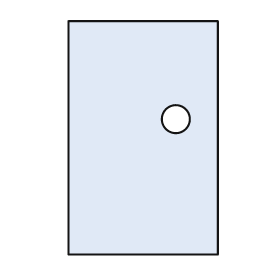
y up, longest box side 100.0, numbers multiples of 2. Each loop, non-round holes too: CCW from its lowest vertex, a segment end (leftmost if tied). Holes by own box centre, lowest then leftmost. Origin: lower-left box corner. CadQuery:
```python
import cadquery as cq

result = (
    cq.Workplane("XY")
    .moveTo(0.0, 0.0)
    .lineTo(64.0, 0.0)
    .lineTo(64.0, 100.0)
    .lineTo(0.0, 100.0)
    .close()
    .moveTo(46.0, 58.0)
    .circle(6.0)
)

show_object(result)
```